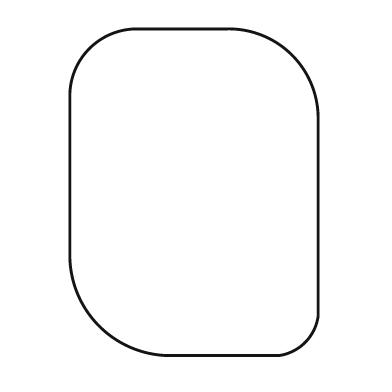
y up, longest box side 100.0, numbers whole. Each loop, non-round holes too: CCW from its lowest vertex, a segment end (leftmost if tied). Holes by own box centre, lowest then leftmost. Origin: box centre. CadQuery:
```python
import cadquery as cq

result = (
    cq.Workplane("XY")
    .moveTo(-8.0, -50.0)
    .lineTo(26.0, -50.0)
    .threePointArc((34.0, -46.0), (38.0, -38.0))
    .lineTo(38.0, 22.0)
    .threePointArc((30.0, 42.0), (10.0, 50.0))
    .lineTo(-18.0, 50.0)
    .threePointArc((-32.0, 44.0), (-38.0, 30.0))
    .lineTo(-38.0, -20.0)
    .threePointArc((-29.0, -41.0), (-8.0, -50.0))
    .close()
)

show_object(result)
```